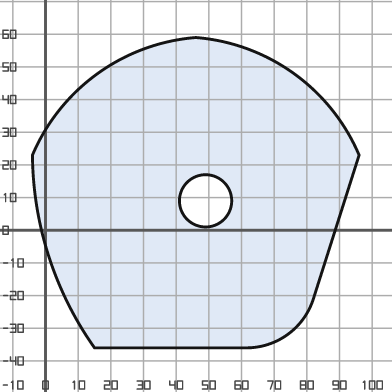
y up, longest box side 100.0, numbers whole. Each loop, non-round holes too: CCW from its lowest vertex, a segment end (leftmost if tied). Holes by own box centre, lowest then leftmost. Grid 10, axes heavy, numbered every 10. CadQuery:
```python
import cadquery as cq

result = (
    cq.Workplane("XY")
    .moveTo(15.0, -36.0)
    .lineTo(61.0, -36.0)
    .threePointArc((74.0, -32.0), (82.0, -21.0))
    .lineTo(96.0, 23.0)
    .threePointArc((76.0, 48.0), (46.0, 59.0))
    .threePointArc((16.0, 48.0), (-4.0, 23.0))
    .threePointArc((1.0, -8.0), (15.0, -36.0))
    .close()
    .moveTo(49.0, 9.0)
    .circle(8.0)
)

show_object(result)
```